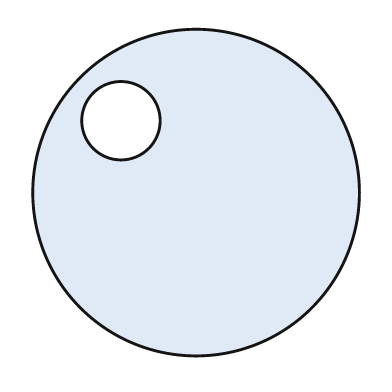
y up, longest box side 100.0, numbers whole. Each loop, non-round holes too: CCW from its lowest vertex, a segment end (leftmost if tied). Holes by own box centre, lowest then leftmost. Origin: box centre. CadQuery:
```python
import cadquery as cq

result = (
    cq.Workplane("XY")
    .moveTo(0.0, 0.0)
    .circle(50.0)
    .moveTo(-23.0, 22.0)
    .circle(12.0)
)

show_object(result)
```